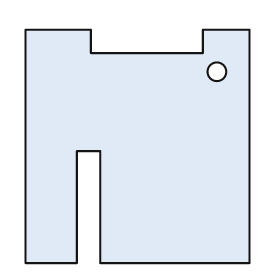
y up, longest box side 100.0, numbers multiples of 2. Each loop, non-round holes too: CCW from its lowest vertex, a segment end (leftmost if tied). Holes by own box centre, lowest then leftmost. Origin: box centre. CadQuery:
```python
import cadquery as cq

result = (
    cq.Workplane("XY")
    .moveTo(-48.0, -50.0)
    .lineTo(-26.0, -50.0)
    .lineTo(-26.0, -2.0)
    .lineTo(-16.0, -2.0)
    .lineTo(-16.0, -50.0)
    .lineTo(48.0, -50.0)
    .lineTo(48.0, 50.0)
    .lineTo(28.0, 50.0)
    .lineTo(28.0, 40.0)
    .lineTo(-20.0, 40.0)
    .lineTo(-20.0, 50.0)
    .lineTo(-48.0, 50.0)
    .close()
    .moveTo(34.0, 32.0)
    .circle(4.0)
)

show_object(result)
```